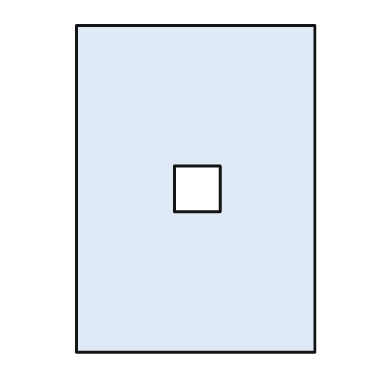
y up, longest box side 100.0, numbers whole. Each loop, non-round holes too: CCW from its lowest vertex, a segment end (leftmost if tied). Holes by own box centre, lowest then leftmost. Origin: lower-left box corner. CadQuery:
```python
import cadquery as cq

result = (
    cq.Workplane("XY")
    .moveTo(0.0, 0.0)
    .lineTo(73.0, 0.0)
    .lineTo(73.0, 100.0)
    .lineTo(0.0, 100.0)
    .close()
    .moveTo(30.0, 43.0)
    .lineTo(44.0, 43.0)
    .lineTo(44.0, 57.0)
    .lineTo(30.0, 57.0)
    .close()
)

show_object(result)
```